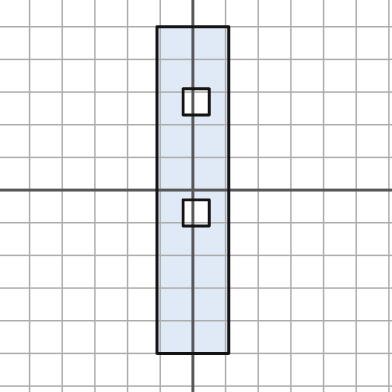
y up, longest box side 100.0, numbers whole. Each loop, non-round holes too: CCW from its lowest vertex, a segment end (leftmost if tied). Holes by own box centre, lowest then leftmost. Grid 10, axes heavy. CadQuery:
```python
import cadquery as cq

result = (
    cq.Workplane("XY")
    .moveTo(-11.0, -50.0)
    .lineTo(11.0, -50.0)
    .lineTo(11.0, 50.0)
    .lineTo(-11.0, 50.0)
    .close()
    .moveTo(-3.0, -11.0)
    .lineTo(5.0, -11.0)
    .lineTo(5.0, -3.0)
    .lineTo(-3.0, -3.0)
    .close()
    .moveTo(-3.0, 23.0)
    .lineTo(5.0, 23.0)
    .lineTo(5.0, 31.0)
    .lineTo(-3.0, 31.0)
    .close()
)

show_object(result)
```